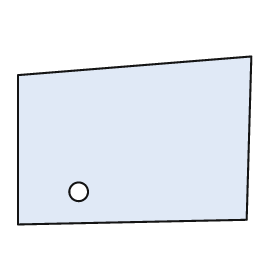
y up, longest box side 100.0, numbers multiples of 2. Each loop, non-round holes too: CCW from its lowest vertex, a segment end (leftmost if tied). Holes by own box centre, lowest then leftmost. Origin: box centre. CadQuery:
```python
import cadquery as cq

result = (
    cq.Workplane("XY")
    .moveTo(-50.0, -36.0)
    .lineTo(48.0, -34.0)
    .lineTo(50.0, 36.0)
    .lineTo(-50.0, 28.0)
    .close()
    .moveTo(-24.0, -22.0)
    .circle(4.0)
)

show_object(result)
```